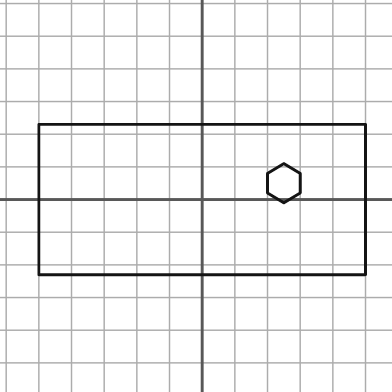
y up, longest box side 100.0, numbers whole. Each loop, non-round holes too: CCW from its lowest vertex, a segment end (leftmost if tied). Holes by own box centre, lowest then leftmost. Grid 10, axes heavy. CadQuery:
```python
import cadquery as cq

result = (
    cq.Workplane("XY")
    .moveTo(-50.0, -23.0)
    .lineTo(50.0, -23.0)
    .lineTo(50.0, 23.0)
    .lineTo(-50.0, 23.0)
    .close()
    .moveTo(25.0, -1.0)
    .lineTo(30.0, 2.0)
    .lineTo(30.0, 8.0)
    .lineTo(25.0, 11.0)
    .lineTo(20.0, 8.0)
    .lineTo(20.0, 2.0)
    .close()
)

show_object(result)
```